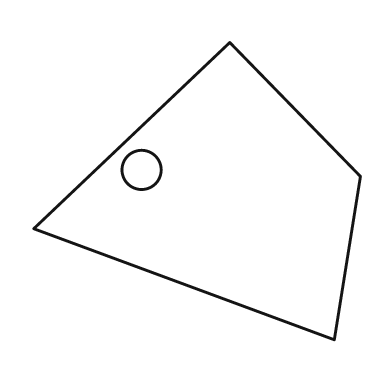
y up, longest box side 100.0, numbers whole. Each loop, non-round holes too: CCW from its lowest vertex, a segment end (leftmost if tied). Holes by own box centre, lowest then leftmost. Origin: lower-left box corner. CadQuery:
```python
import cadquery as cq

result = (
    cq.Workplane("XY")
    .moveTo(92.0, 0.0)
    .lineTo(100.0, 50.0)
    .lineTo(60.0, 91.0)
    .lineTo(0.0, 34.0)
    .close()
    .moveTo(33.0, 52.0)
    .circle(6.0)
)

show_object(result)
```